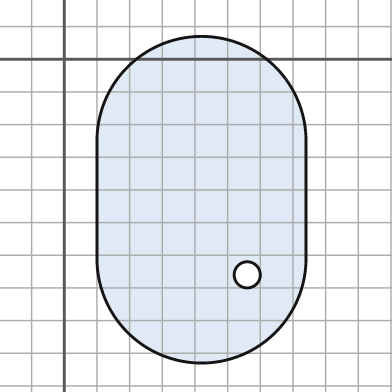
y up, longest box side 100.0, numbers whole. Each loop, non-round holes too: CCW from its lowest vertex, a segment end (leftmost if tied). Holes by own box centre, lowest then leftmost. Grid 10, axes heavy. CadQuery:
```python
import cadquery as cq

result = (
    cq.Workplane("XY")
    .moveTo(10.0, -61.0)
    .threePointArc((42.0, -93.0), (74.0, -61.0))
    .lineTo(74.0, -25.0)
    .threePointArc((42.0, 7.0), (10.0, -25.0))
    .close()
    .moveTo(56.0, -66.0)
    .circle(4.0)
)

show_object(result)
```